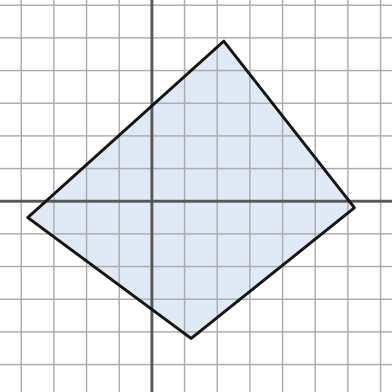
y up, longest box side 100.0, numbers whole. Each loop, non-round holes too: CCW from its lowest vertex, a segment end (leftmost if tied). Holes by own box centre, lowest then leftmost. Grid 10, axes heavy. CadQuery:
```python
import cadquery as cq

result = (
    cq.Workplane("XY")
    .moveTo(12.0, -42.0)
    .lineTo(62.0, -2.0)
    .lineTo(22.0, 49.0)
    .lineTo(-38.0, -5.0)
    .close()
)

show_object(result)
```